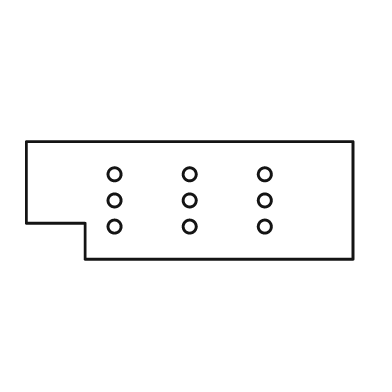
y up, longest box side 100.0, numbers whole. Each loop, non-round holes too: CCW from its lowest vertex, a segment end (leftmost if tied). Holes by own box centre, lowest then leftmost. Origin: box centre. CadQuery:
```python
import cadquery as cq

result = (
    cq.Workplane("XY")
    .moveTo(-32.0, -18.0)
    .lineTo(50.0, -18.0)
    .lineTo(50.0, 18.0)
    .lineTo(-50.0, 18.0)
    .lineTo(-50.0, -7.0)
    .lineTo(-32.0, -7.0)
    .close()
    .moveTo(-23.0, -8.0)
    .circle(2.0)
    .moveTo(0.0, -8.0)
    .circle(2.0)
    .moveTo(23.0, -8.0)
    .circle(2.0)
    .moveTo(-23.0, 0.0)
    .circle(2.0)
    .moveTo(0.0, 0.0)
    .circle(2.0)
    .moveTo(23.0, 0.0)
    .circle(2.0)
    .moveTo(-23.0, 8.0)
    .circle(2.0)
    .moveTo(0.0, 8.0)
    .circle(2.0)
    .moveTo(23.0, 8.0)
    .circle(2.0)
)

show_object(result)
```